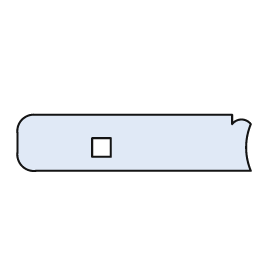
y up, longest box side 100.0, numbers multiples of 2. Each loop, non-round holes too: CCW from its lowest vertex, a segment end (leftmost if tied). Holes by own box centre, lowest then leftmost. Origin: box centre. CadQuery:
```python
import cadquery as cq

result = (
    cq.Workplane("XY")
    .moveTo(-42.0, -12.0)
    .lineTo(50.0, -12.0)
    .threePointArc((48.0, -2.0), (50.0, 8.0))
    .threePointArc((46.0, 10.0), (42.0, 8.0))
    .lineTo(42.0, 12.0)
    .lineTo(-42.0, 12.0)
    .threePointArc((-48.0, 10.0), (-50.0, 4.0))
    .lineTo(-50.0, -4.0)
    .threePointArc((-48.0, -10.0), (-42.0, -12.0))
    .close()
    .moveTo(-18.0, -6.0)
    .lineTo(-10.0, -6.0)
    .lineTo(-10.0, 2.0)
    .lineTo(-18.0, 2.0)
    .close()
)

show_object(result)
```